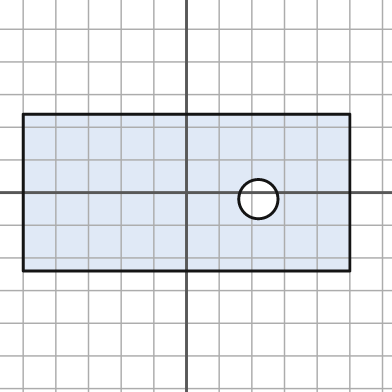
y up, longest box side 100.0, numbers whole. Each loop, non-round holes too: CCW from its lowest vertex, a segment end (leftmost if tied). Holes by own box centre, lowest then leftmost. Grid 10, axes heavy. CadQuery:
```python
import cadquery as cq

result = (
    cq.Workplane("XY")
    .moveTo(-50.0, -24.0)
    .lineTo(50.0, -24.0)
    .lineTo(50.0, 24.0)
    .lineTo(-50.0, 24.0)
    .close()
    .moveTo(22.0, -2.0)
    .circle(6.0)
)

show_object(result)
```